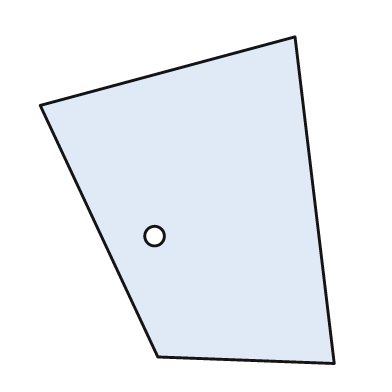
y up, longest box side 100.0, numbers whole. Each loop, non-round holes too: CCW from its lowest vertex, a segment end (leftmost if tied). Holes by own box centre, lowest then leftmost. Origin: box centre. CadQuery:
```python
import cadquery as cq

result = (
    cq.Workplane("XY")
    .moveTo(45.0, -50.0)
    .lineTo(33.0, 50.0)
    .lineTo(-45.0, 29.0)
    .lineTo(-9.0, -48.0)
    .close()
    .moveTo(-10.0, -11.0)
    .circle(3.0)
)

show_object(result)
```